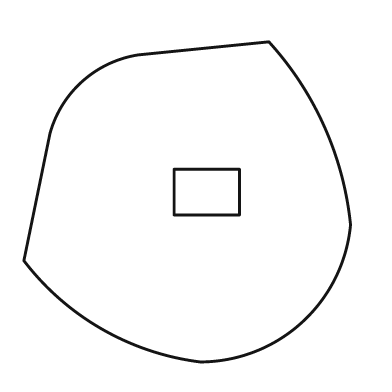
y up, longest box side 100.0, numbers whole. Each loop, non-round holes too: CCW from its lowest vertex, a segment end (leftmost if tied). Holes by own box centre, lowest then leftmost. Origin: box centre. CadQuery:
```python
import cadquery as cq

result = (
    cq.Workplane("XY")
    .moveTo(4.0, -49.0)
    .threePointArc((35.0, -37.0), (50.0, -7.0))
    .threePointArc((42.0, 23.0), (25.0, 49.0))
    .lineTo(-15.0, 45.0)
    .threePointArc((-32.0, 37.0), (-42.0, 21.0))
    .lineTo(-50.0, -18.0)
    .threePointArc((-26.0, -39.0), (4.0, -49.0))
    .close()
    .moveTo(-4.0, -4.0)
    .lineTo(16.0, -4.0)
    .lineTo(16.0, 10.0)
    .lineTo(-4.0, 10.0)
    .close()
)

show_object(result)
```